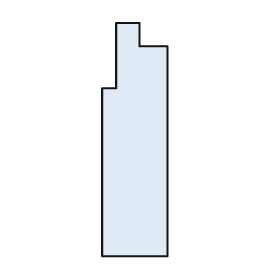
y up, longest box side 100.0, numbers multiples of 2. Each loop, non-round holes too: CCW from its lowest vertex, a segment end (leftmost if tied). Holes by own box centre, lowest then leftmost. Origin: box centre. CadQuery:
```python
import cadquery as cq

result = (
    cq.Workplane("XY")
    .moveTo(-14.0, -50.0)
    .lineTo(14.0, -50.0)
    .lineTo(14.0, 40.0)
    .lineTo(2.0, 40.0)
    .lineTo(2.0, 50.0)
    .lineTo(-8.0, 50.0)
    .lineTo(-8.0, 22.0)
    .lineTo(-14.0, 22.0)
    .close()
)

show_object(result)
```